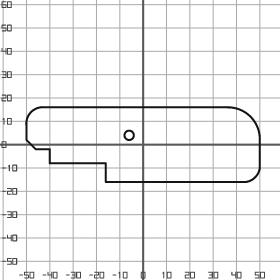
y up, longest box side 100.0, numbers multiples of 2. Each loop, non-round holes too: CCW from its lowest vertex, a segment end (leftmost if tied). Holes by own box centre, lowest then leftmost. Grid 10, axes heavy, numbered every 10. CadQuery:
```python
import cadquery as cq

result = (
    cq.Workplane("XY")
    .moveTo(-16.0, -16.0)
    .lineTo(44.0, -16.0)
    .threePointArc((48.0, -14.0), (50.0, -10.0))
    .lineTo(50.0, 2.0)
    .threePointArc((46.0, 12.0), (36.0, 16.0))
    .lineTo(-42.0, 16.0)
    .threePointArc((-48.0, 14.0), (-50.0, 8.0))
    .lineTo(-50.0, 2.0)
    .lineTo(-46.0, -2.0)
    .lineTo(-40.0, -2.0)
    .lineTo(-40.0, -8.0)
    .lineTo(-16.0, -8.0)
    .close()
    .moveTo(-6.0, 4.0)
    .circle(2.0)
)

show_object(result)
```